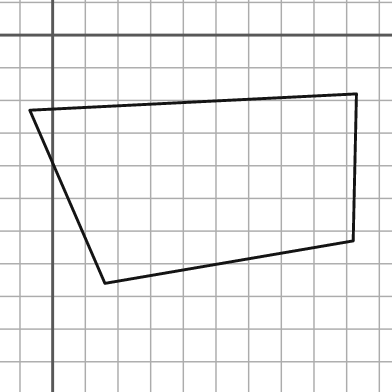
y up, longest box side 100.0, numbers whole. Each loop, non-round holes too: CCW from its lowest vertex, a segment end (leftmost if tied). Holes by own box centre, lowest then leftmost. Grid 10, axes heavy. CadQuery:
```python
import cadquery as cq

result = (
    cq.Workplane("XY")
    .moveTo(16.0, -76.0)
    .lineTo(92.0, -63.0)
    .lineTo(93.0, -18.0)
    .lineTo(-7.0, -23.0)
    .close()
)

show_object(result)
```